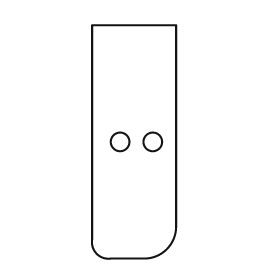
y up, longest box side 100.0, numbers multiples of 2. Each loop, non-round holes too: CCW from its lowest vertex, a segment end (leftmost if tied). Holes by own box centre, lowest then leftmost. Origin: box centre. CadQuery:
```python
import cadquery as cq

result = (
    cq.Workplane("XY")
    .moveTo(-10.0, -50.0)
    .lineTo(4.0, -50.0)
    .threePointArc((14.0, -46.0), (18.0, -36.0))
    .lineTo(18.0, 50.0)
    .lineTo(-18.0, 50.0)
    .lineTo(-18.0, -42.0)
    .threePointArc((-16.0, -48.0), (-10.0, -50.0))
    .close()
    .moveTo(-6.0, 0.0)
    .circle(4.0)
    .moveTo(8.0, 0.0)
    .circle(4.0)
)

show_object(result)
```